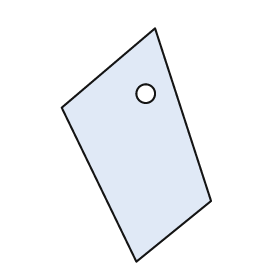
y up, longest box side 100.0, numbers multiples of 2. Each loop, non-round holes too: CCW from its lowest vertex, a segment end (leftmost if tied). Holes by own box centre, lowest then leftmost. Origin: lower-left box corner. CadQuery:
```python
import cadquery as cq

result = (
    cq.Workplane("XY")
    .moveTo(32.0, 0.0)
    .lineTo(64.0, 26.0)
    .lineTo(40.0, 100.0)
    .lineTo(0.0, 66.0)
    .close()
    .moveTo(36.0, 72.0)
    .circle(4.0)
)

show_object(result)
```